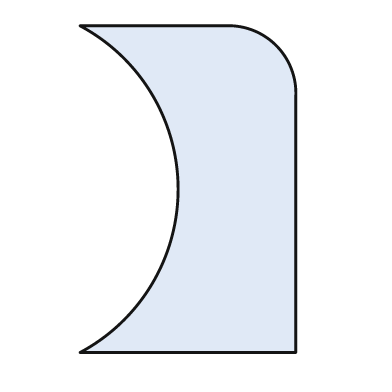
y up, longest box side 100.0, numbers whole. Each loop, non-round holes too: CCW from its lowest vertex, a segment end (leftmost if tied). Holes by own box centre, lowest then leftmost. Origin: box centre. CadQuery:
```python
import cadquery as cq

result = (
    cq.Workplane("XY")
    .moveTo(-33.0, -50.0)
    .lineTo(33.0, -50.0)
    .lineTo(33.0, 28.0)
    .threePointArc((27.0, 44.0), (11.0, 50.0))
    .lineTo(-33.0, 50.0)
    .threePointArc((-3.0, 0.0), (-33.0, -50.0))
    .close()
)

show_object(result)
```